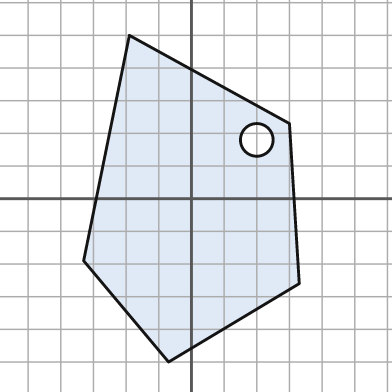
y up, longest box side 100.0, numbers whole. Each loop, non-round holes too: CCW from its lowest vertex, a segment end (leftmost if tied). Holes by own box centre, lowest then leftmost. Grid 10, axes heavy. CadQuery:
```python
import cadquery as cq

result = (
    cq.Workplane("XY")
    .moveTo(-7.0, -50.0)
    .lineTo(33.0, -26.0)
    .lineTo(30.0, 23.0)
    .lineTo(-19.0, 50.0)
    .lineTo(-33.0, -19.0)
    .close()
    .moveTo(20.0, 18.0)
    .circle(5.0)
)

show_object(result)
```